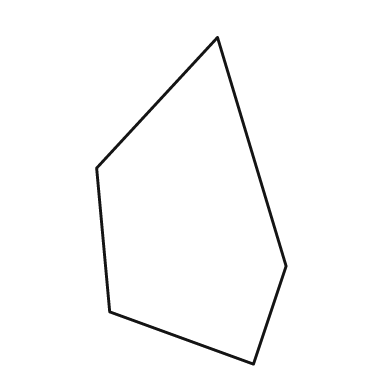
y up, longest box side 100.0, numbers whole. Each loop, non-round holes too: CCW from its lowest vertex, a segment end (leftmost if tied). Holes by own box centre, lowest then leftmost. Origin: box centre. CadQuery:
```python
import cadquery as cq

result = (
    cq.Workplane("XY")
    .moveTo(19.0, -50.0)
    .lineTo(29.0, -20.0)
    .lineTo(8.0, 50.0)
    .lineTo(-29.0, 10.0)
    .lineTo(-25.0, -34.0)
    .close()
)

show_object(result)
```